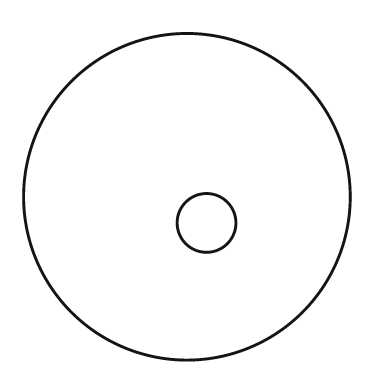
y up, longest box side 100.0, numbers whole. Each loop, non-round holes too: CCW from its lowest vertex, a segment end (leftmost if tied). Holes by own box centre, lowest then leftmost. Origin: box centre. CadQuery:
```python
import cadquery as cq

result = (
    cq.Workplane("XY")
    .moveTo(0.0, 0.0)
    .circle(50.0)
    .moveTo(6.0, -8.0)
    .circle(9.0)
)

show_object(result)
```